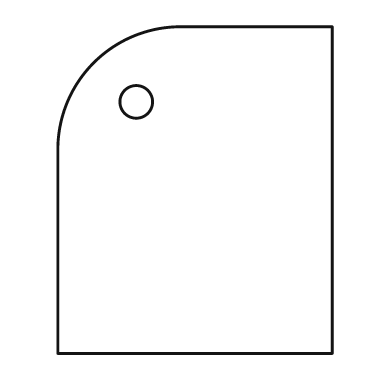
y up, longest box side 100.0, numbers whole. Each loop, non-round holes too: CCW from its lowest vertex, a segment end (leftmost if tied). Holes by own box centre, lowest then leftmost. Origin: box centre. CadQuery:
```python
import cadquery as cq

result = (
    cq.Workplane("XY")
    .moveTo(-42.0, -50.0)
    .lineTo(42.0, -50.0)
    .lineTo(42.0, 50.0)
    .lineTo(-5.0, 50.0)
    .threePointArc((-31.0, 39.0), (-42.0, 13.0))
    .close()
    .moveTo(-18.0, 27.0)
    .circle(5.0)
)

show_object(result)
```